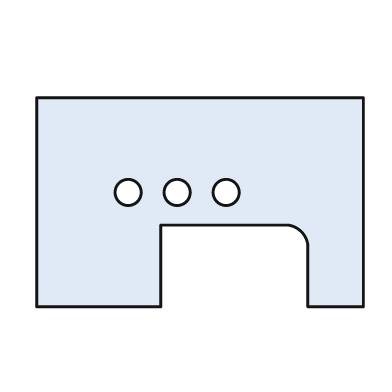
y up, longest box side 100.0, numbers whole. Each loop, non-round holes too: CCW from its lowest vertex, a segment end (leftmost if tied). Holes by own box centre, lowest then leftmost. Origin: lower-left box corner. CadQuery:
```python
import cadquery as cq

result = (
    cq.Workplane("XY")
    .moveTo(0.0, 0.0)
    .lineTo(38.0, 0.0)
    .lineTo(38.0, 25.0)
    .lineTo(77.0, 25.0)
    .threePointArc((81.0, 23.0), (83.0, 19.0))
    .lineTo(83.0, 0.0)
    .lineTo(100.0, 0.0)
    .lineTo(100.0, 64.0)
    .lineTo(0.0, 64.0)
    .close()
    .moveTo(28.0, 35.0)
    .circle(4.0)
    .moveTo(43.0, 35.0)
    .circle(4.0)
    .moveTo(58.0, 35.0)
    .circle(4.0)
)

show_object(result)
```